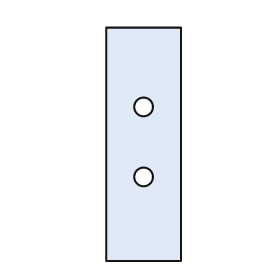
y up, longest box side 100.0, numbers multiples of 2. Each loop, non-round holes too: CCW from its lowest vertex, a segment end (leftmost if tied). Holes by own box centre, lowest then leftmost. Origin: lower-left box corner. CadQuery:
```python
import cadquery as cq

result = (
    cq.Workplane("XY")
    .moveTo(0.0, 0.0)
    .lineTo(32.0, 0.0)
    .lineTo(32.0, 100.0)
    .lineTo(0.0, 100.0)
    .close()
    .moveTo(16.0, 36.0)
    .circle(4.0)
    .moveTo(16.0, 66.0)
    .circle(4.0)
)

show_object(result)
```